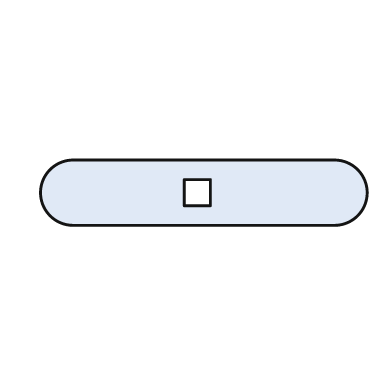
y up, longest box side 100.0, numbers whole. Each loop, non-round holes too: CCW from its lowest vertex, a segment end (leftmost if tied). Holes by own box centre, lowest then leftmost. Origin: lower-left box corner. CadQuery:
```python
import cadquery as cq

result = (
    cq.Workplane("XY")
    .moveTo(10.0, 0.0)
    .lineTo(90.0, 0.0)
    .threePointArc((100.0, 10.0), (90.0, 20.0))
    .lineTo(10.0, 20.0)
    .threePointArc((0.0, 10.0), (10.0, 0.0))
    .close()
    .moveTo(44.0, 6.0)
    .lineTo(52.0, 6.0)
    .lineTo(52.0, 14.0)
    .lineTo(44.0, 14.0)
    .close()
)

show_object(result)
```